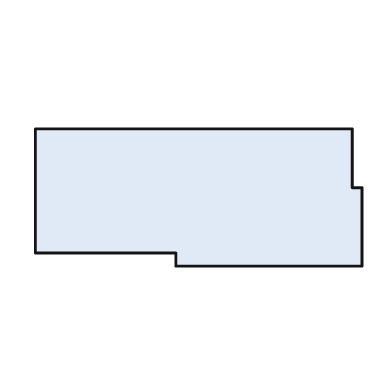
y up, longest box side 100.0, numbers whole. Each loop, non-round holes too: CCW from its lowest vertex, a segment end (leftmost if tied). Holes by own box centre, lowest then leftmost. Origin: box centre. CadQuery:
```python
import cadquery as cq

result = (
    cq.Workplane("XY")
    .moveTo(-7.0, -21.0)
    .lineTo(50.0, -21.0)
    .lineTo(50.0, 3.0)
    .lineTo(47.0, 3.0)
    .lineTo(47.0, 21.0)
    .lineTo(-50.0, 21.0)
    .lineTo(-50.0, -17.0)
    .lineTo(-7.0, -17.0)
    .close()
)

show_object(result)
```